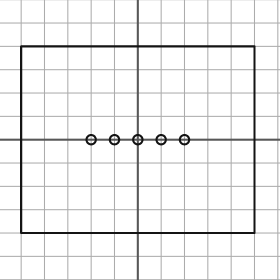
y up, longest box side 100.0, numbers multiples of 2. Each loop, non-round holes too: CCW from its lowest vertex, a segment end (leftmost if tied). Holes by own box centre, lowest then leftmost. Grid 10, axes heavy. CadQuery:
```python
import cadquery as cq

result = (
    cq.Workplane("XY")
    .moveTo(-50.0, -40.0)
    .lineTo(50.0, -40.0)
    .lineTo(50.0, 40.0)
    .lineTo(-50.0, 40.0)
    .close()
    .moveTo(-20.0, 0.0)
    .circle(2.0)
    .moveTo(-10.0, 0.0)
    .circle(2.0)
    .moveTo(0.0, 0.0)
    .circle(2.0)
    .moveTo(10.0, 0.0)
    .circle(2.0)
    .moveTo(20.0, 0.0)
    .circle(2.0)
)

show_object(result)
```